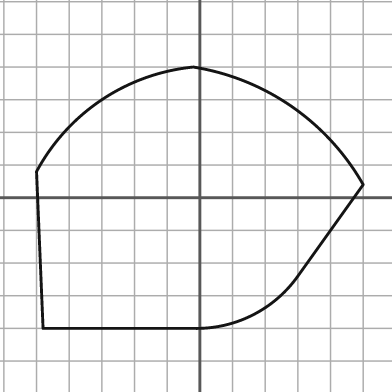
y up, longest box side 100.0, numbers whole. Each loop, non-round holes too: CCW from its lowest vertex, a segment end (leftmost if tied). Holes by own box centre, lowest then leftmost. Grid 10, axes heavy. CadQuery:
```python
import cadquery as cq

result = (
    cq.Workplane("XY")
    .moveTo(-48.0, -40.0)
    .lineTo(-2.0, -40.0)
    .threePointArc((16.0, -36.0), (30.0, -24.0))
    .lineTo(50.0, 4.0)
    .threePointArc((28.0, 28.0), (-2.0, 40.0))
    .threePointArc((-30.0, 30.0), (-50.0, 8.0))
    .close()
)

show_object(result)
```